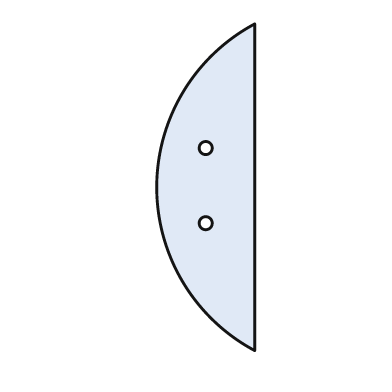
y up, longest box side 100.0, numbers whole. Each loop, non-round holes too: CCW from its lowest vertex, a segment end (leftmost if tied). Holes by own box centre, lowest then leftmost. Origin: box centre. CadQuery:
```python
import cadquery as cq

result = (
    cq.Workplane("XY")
    .moveTo(15.0, -50.0)
    .lineTo(15.0, 50.0)
    .threePointArc((-15.0, 0.0), (15.0, -50.0))
    .close()
    .moveTo(0.0, -11.0)
    .circle(2.0)
    .moveTo(0.0, 12.0)
    .circle(2.0)
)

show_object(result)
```